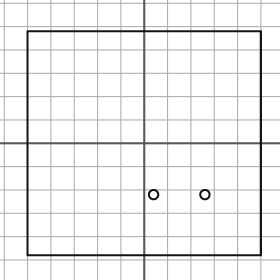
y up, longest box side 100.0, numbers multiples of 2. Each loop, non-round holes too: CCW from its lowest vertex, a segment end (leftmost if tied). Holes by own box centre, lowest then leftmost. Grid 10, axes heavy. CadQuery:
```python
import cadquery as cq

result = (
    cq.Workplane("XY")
    .moveTo(-50.0, -48.0)
    .lineTo(50.0, -48.0)
    .lineTo(50.0, 48.0)
    .lineTo(-50.0, 48.0)
    .close()
    .moveTo(4.0, -22.0)
    .circle(2.0)
    .moveTo(26.0, -22.0)
    .circle(2.0)
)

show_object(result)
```